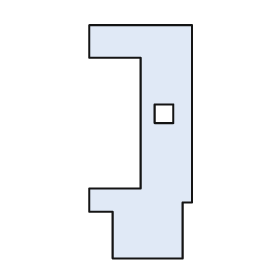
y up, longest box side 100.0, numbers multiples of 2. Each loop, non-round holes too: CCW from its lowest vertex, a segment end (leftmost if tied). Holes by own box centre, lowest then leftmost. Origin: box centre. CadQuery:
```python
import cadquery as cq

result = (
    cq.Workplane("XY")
    .moveTo(-12.0, -50.0)
    .lineTo(18.0, -50.0)
    .lineTo(18.0, -26.0)
    .lineTo(22.0, -26.0)
    .lineTo(22.0, 50.0)
    .lineTo(-22.0, 50.0)
    .lineTo(-22.0, 36.0)
    .lineTo(0.0, 36.0)
    .lineTo(0.0, -20.0)
    .lineTo(-22.0, -20.0)
    .lineTo(-22.0, -30.0)
    .lineTo(-12.0, -30.0)
    .close()
    .moveTo(6.0, 8.0)
    .lineTo(14.0, 8.0)
    .lineTo(14.0, 16.0)
    .lineTo(6.0, 16.0)
    .close()
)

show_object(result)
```